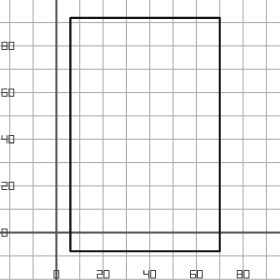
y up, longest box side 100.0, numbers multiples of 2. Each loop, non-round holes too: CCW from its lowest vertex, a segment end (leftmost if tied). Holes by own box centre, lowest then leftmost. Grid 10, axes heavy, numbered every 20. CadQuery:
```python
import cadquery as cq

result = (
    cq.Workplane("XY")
    .moveTo(6.0, -8.0)
    .lineTo(70.0, -8.0)
    .lineTo(70.0, 92.0)
    .lineTo(6.0, 92.0)
    .close()
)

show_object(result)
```